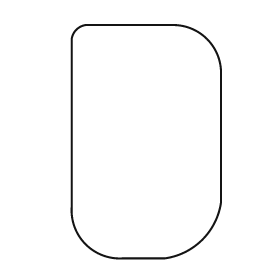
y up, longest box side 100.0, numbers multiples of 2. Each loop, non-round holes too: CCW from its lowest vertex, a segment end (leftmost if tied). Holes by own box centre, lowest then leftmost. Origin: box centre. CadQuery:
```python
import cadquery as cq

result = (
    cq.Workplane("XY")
    .moveTo(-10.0, -50.0)
    .lineTo(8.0, -50.0)
    .threePointArc((24.0, -42.0), (32.0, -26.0))
    .lineTo(32.0, 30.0)
    .threePointArc((26.0, 44.0), (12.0, 50.0))
    .lineTo(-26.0, 50.0)
    .threePointArc((-30.0, 48.0), (-32.0, 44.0))
    .lineTo(-32.0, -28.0)
    .threePointArc((-26.0, -44.0), (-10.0, -50.0))
    .close()
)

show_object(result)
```